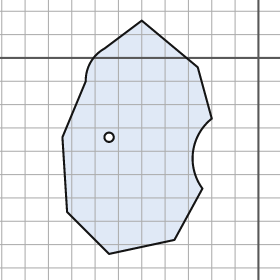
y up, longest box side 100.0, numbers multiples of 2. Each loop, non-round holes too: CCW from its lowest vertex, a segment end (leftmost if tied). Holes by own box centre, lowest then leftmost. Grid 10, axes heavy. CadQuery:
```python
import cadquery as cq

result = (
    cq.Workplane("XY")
    .moveTo(-64.0, -84.0)
    .lineTo(-36.0, -78.0)
    .lineTo(-24.0, -56.0)
    .threePointArc((-28.0, -40.0), (-20.0, -26.0))
    .lineTo(-26.0, -4.0)
    .lineTo(-50.0, 16.0)
    .lineTo(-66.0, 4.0)
    .threePointArc((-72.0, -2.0), (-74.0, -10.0))
    .lineTo(-84.0, -34.0)
    .lineTo(-82.0, -66.0)
    .close()
    .moveTo(-64.0, -34.0)
    .circle(2.0)
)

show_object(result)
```